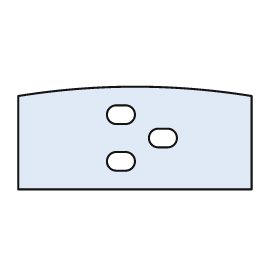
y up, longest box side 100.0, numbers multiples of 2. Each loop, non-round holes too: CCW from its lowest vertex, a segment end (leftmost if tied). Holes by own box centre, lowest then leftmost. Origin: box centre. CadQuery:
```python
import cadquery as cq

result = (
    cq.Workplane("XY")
    .moveTo(-50.0, -22.0)
    .lineTo(50.0, -22.0)
    .lineTo(50.0, 18.0)
    .threePointArc((0.0, 22.0), (-50.0, 18.0))
    .close()
    .moveTo(-8.0, -14.0)
    .lineTo(-4.0, -14.0)
    .threePointArc((0.0, -10.0), (-4.0, -6.0))
    .lineTo(-8.0, -6.0)
    .threePointArc((-12.0, -10.0), (-8.0, -14.0))
    .close()
    .moveTo(10.0, -4.0)
    .lineTo(14.0, -4.0)
    .threePointArc((18.0, 0.0), (14.0, 4.0))
    .lineTo(10.0, 4.0)
    .threePointArc((6.0, 0.0), (10.0, -4.0))
    .close()
    .moveTo(-8.0, 6.0)
    .lineTo(-4.0, 6.0)
    .threePointArc((0.0, 10.0), (-4.0, 14.0))
    .lineTo(-8.0, 14.0)
    .threePointArc((-12.0, 10.0), (-8.0, 6.0))
    .close()
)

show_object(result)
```